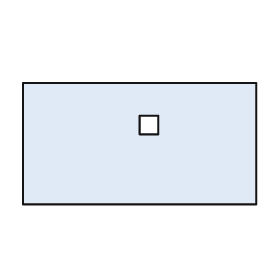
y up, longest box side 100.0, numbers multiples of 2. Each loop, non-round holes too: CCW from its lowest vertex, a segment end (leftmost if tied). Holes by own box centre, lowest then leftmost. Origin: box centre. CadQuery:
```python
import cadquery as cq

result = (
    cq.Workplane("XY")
    .moveTo(-50.0, -26.0)
    .lineTo(50.0, -26.0)
    .lineTo(50.0, 26.0)
    .lineTo(-50.0, 26.0)
    .close()
    .moveTo(0.0, 4.0)
    .lineTo(8.0, 4.0)
    .lineTo(8.0, 12.0)
    .lineTo(0.0, 12.0)
    .close()
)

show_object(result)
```